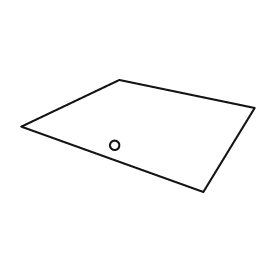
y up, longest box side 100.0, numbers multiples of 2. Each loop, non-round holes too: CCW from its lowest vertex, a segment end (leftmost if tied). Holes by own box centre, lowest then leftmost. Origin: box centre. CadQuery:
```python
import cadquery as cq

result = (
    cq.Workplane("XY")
    .moveTo(28.0, -24.0)
    .lineTo(50.0, 12.0)
    .lineTo(-8.0, 24.0)
    .lineTo(-50.0, 4.0)
    .close()
    .moveTo(-10.0, -4.0)
    .circle(2.0)
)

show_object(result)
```